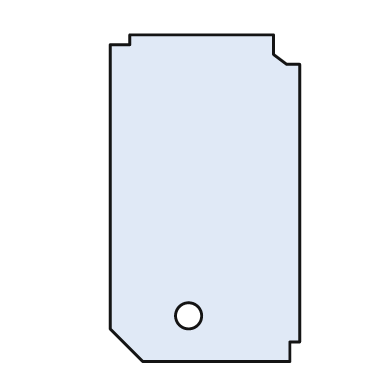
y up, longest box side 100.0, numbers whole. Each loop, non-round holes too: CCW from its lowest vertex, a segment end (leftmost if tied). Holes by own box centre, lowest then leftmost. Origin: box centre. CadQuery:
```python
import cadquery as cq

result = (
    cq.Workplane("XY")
    .moveTo(-19.0, -50.0)
    .lineTo(26.0, -50.0)
    .lineTo(26.0, -44.0)
    .lineTo(29.0, -44.0)
    .lineTo(29.0, 41.0)
    .lineTo(25.0, 41.0)
    .lineTo(21.0, 44.0)
    .lineTo(21.0, 50.0)
    .lineTo(-23.0, 50.0)
    .lineTo(-23.0, 47.0)
    .lineTo(-29.0, 47.0)
    .lineTo(-29.0, -40.0)
    .close()
    .moveTo(-5.0, -36.0)
    .circle(4.0)
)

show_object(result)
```